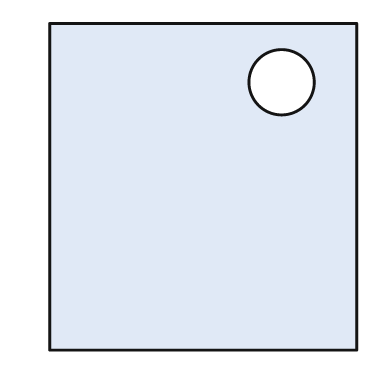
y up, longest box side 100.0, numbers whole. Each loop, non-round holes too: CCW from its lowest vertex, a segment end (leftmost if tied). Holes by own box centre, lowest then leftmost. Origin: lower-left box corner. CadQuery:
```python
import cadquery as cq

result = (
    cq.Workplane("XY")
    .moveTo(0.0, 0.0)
    .lineTo(94.0, 0.0)
    .lineTo(94.0, 100.0)
    .lineTo(0.0, 100.0)
    .close()
    .moveTo(71.0, 82.0)
    .circle(10.0)
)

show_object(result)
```